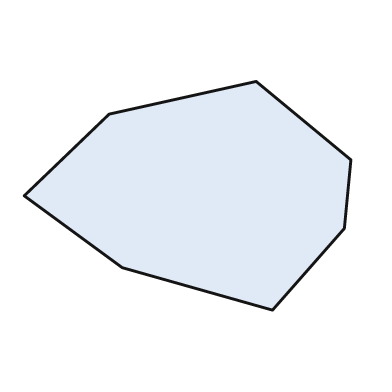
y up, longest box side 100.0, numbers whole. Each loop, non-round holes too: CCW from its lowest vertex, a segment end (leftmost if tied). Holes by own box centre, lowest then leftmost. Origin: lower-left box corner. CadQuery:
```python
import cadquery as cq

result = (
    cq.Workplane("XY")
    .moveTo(76.0, 0.0)
    .lineTo(98.0, 25.0)
    .lineTo(100.0, 46.0)
    .lineTo(71.0, 70.0)
    .lineTo(26.0, 60.0)
    .lineTo(0.0, 35.0)
    .lineTo(30.0, 13.0)
    .close()
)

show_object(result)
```